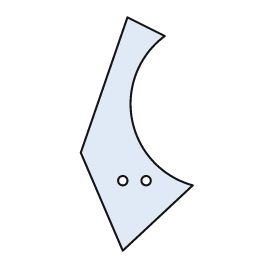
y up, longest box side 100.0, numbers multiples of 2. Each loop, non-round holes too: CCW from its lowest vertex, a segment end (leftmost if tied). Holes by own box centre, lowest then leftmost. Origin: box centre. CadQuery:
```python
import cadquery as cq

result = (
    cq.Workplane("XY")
    .moveTo(-6.0, -50.0)
    .lineTo(24.0, -22.0)
    .threePointArc((-2.0, 6.0), (12.0, 42.0))
    .lineTo(-4.0, 50.0)
    .lineTo(-24.0, -8.0)
    .close()
    .moveTo(-6.0, -20.0)
    .circle(2.0)
    .moveTo(4.0, -20.0)
    .circle(2.0)
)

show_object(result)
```